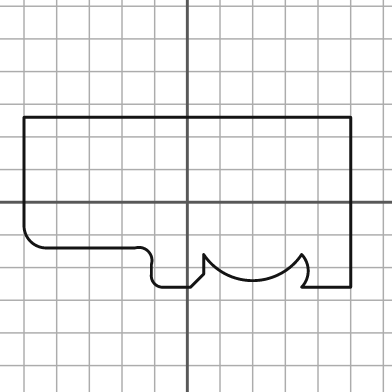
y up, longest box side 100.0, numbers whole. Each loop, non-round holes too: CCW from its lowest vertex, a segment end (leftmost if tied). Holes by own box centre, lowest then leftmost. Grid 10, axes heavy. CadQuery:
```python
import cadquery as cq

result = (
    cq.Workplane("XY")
    .moveTo(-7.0, -26.0)
    .lineTo(1.0, -26.0)
    .lineTo(5.0, -22.0)
    .lineTo(5.0, -16.0)
    .threePointArc((20.0, -24.0), (35.0, -16.0))
    .threePointArc((37.0, -21.0), (35.0, -26.0))
    .lineTo(50.0, -26.0)
    .lineTo(50.0, 26.0)
    .lineTo(-50.0, 26.0)
    .lineTo(-50.0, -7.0)
    .threePointArc((-48.0, -12.0), (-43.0, -14.0))
    .lineTo(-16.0, -14.0)
    .threePointArc((-12.0, -15.0), (-11.0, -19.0))
    .lineTo(-11.0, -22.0)
    .threePointArc((-10.0, -25.0), (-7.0, -26.0))
    .close()
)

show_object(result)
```